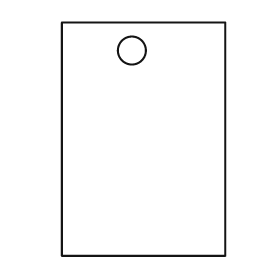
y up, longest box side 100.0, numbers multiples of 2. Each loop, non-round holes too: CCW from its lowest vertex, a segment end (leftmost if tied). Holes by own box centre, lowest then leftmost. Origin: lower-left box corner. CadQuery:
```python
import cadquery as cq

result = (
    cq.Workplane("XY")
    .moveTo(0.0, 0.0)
    .lineTo(70.0, 0.0)
    .lineTo(70.0, 100.0)
    .lineTo(0.0, 100.0)
    .close()
    .moveTo(30.0, 88.0)
    .circle(6.0)
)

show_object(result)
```